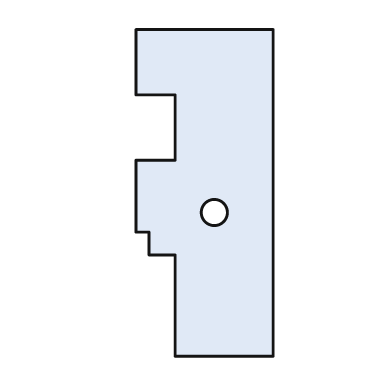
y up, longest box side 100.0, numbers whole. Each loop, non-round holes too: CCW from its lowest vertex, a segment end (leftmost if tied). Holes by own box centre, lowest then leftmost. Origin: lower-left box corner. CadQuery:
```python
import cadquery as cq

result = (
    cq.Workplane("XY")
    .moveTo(12.0, 0.0)
    .lineTo(42.0, 0.0)
    .lineTo(42.0, 100.0)
    .lineTo(0.0, 100.0)
    .lineTo(0.0, 80.0)
    .lineTo(12.0, 80.0)
    .lineTo(12.0, 60.0)
    .lineTo(0.0, 60.0)
    .lineTo(0.0, 38.0)
    .lineTo(4.0, 38.0)
    .lineTo(4.0, 31.0)
    .lineTo(12.0, 31.0)
    .close()
    .moveTo(24.0, 44.0)
    .circle(4.0)
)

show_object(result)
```